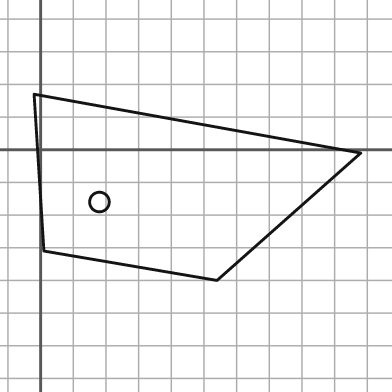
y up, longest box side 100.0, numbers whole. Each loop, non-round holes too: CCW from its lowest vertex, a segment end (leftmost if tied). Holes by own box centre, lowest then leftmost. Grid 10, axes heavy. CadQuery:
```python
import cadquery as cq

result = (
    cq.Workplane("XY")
    .moveTo(54.0, -40.0)
    .lineTo(98.0, -1.0)
    .lineTo(-2.0, 17.0)
    .lineTo(1.0, -31.0)
    .close()
    .moveTo(18.0, -16.0)
    .circle(3.0)
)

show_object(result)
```